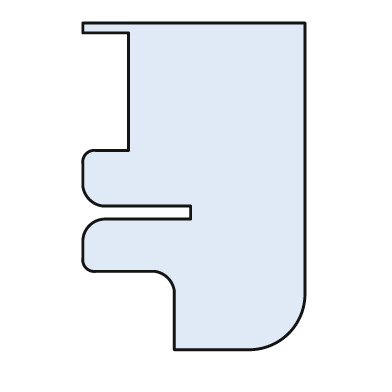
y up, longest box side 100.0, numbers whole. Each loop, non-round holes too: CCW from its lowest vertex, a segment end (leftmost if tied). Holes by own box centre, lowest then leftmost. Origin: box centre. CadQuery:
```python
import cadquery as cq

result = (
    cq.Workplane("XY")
    .moveTo(-6.0, -50.0)
    .lineTo(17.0, -50.0)
    .threePointArc((29.0, -45.0), (34.0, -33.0))
    .lineTo(34.0, 50.0)
    .lineTo(-34.0, 50.0)
    .lineTo(-34.0, 47.0)
    .lineTo(-20.0, 47.0)
    .lineTo(-20.0, 11.0)
    .lineTo(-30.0, 11.0)
    .threePointArc((-33.0, 10.0), (-34.0, 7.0))
    .lineTo(-34.0, 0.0)
    .threePointArc((-32.0, -4.0), (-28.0, -6.0))
    .lineTo(-1.0, -6.0)
    .lineTo(-1.0, -10.0)
    .lineTo(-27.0, -10.0)
    .threePointArc((-32.0, -12.0), (-34.0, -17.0))
    .lineTo(-34.0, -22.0)
    .threePointArc((-33.0, -25.0), (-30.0, -26.0))
    .lineTo(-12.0, -26.0)
    .threePointArc((-8.0, -28.0), (-6.0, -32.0))
    .close()
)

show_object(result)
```